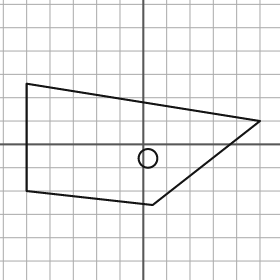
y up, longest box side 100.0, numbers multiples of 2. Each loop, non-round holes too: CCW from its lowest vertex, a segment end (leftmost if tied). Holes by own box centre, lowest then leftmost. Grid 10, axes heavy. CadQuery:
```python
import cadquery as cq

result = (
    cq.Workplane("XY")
    .moveTo(4.0, -26.0)
    .lineTo(50.0, 10.0)
    .lineTo(-50.0, 26.0)
    .lineTo(-50.0, -20.0)
    .close()
    .moveTo(2.0, -6.0)
    .circle(4.0)
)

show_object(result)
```